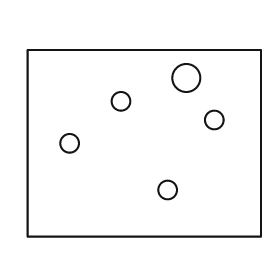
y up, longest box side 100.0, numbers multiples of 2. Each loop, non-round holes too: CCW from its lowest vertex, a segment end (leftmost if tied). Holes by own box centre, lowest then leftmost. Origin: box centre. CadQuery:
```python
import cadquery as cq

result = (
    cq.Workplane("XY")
    .moveTo(-50.0, -40.0)
    .lineTo(50.0, -40.0)
    .lineTo(50.0, 40.0)
    .lineTo(-50.0, 40.0)
    .close()
    .moveTo(10.0, -20.0)
    .circle(4.0)
    .moveTo(-32.0, 0.0)
    .circle(4.0)
    .moveTo(30.0, 10.0)
    .circle(4.0)
    .moveTo(-10.0, 18.0)
    .circle(4.0)
    .moveTo(18.0, 28.0)
    .circle(6.0)
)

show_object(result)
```